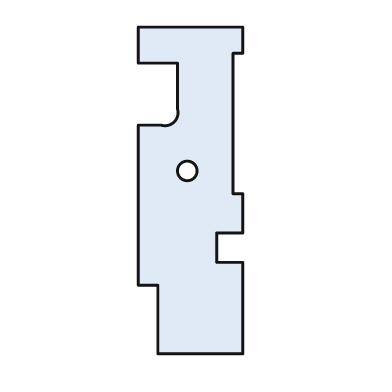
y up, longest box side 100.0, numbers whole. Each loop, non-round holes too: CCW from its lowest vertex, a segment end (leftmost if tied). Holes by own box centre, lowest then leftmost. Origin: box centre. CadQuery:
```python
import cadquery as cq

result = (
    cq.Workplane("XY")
    .moveTo(-10.0, -50.0)
    .lineTo(16.0, -50.0)
    .lineTo(16.0, -22.0)
    .lineTo(8.0, -22.0)
    .lineTo(8.0, -13.0)
    .lineTo(16.0, -13.0)
    .lineTo(16.0, -1.0)
    .lineTo(13.0, -1.0)
    .lineTo(13.0, 42.0)
    .lineTo(16.0, 42.0)
    .lineTo(16.0, 50.0)
    .lineTo(-16.0, 50.0)
    .lineTo(-16.0, 39.0)
    .lineTo(-4.0, 39.0)
    .lineTo(-4.0, 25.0)
    .threePointArc((-5.0, 21.0), (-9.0, 20.0))
    .lineTo(-16.0, 20.0)
    .lineTo(-16.0, -29.0)
    .lineTo(-10.0, -29.0)
    .close()
    .moveTo(-1.0, 6.0)
    .circle(3.0)
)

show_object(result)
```